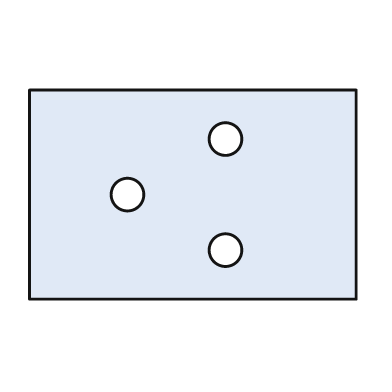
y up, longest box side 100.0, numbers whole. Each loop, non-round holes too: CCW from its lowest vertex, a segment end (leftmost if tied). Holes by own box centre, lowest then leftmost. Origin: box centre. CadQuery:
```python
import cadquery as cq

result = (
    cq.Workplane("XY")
    .moveTo(-50.0, -32.0)
    .lineTo(50.0, -32.0)
    .lineTo(50.0, 32.0)
    .lineTo(-50.0, 32.0)
    .close()
    .moveTo(10.0, -17.0)
    .circle(5.0)
    .moveTo(-20.0, 0.0)
    .circle(5.0)
    .moveTo(10.0, 17.0)
    .circle(5.0)
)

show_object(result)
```